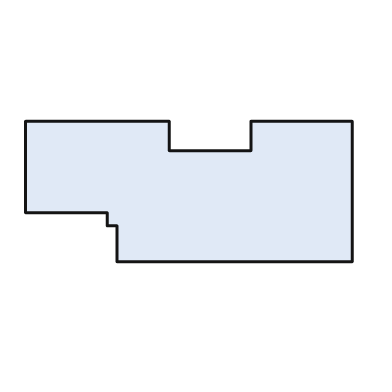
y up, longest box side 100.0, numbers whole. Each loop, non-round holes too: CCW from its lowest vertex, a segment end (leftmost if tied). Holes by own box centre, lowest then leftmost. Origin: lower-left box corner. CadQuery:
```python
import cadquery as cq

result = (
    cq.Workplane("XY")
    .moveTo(28.0, 0.0)
    .lineTo(100.0, 0.0)
    .lineTo(100.0, 43.0)
    .lineTo(69.0, 43.0)
    .lineTo(69.0, 34.0)
    .lineTo(44.0, 34.0)
    .lineTo(44.0, 43.0)
    .lineTo(0.0, 43.0)
    .lineTo(0.0, 15.0)
    .lineTo(25.0, 15.0)
    .lineTo(25.0, 11.0)
    .lineTo(28.0, 11.0)
    .close()
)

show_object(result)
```